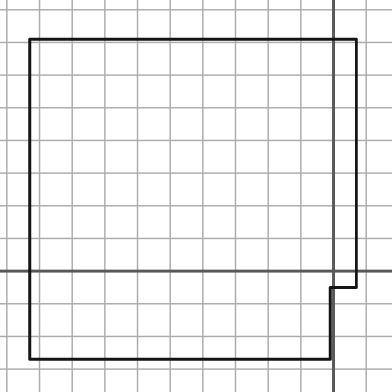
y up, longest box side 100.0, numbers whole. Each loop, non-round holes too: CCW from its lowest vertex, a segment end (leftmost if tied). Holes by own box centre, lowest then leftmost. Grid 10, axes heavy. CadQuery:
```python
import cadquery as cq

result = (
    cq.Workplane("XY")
    .moveTo(-93.0, -27.0)
    .lineTo(-1.0, -27.0)
    .lineTo(-1.0, -5.0)
    .lineTo(7.0, -5.0)
    .lineTo(7.0, 71.0)
    .lineTo(-93.0, 71.0)
    .close()
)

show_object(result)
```